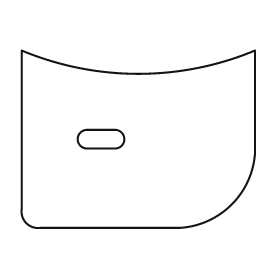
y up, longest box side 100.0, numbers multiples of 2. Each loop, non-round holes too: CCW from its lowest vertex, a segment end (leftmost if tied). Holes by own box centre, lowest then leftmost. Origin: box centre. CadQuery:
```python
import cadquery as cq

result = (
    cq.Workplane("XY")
    .moveTo(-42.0, -38.0)
    .lineTo(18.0, -38.0)
    .threePointArc((40.0, -28.0), (50.0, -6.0))
    .lineTo(50.0, 38.0)
    .threePointArc((0.0, 28.0), (-50.0, 38.0))
    .lineTo(-50.0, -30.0)
    .threePointArc((-48.0, -36.0), (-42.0, -38.0))
    .close()
    .moveTo(-22.0, -4.0)
    .lineTo(-10.0, -4.0)
    .threePointArc((-6.0, 0.0), (-10.0, 4.0))
    .lineTo(-22.0, 4.0)
    .threePointArc((-26.0, 0.0), (-22.0, -4.0))
    .close()
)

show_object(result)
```